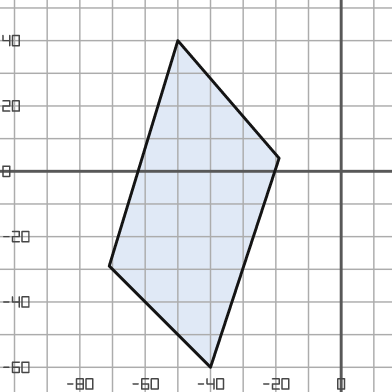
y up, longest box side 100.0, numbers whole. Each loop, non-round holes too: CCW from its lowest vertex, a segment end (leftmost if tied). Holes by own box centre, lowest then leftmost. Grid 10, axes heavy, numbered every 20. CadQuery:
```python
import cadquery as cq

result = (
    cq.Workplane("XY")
    .moveTo(-40.0, -60.0)
    .lineTo(-19.0, 4.0)
    .lineTo(-50.0, 40.0)
    .lineTo(-71.0, -29.0)
    .close()
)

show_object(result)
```